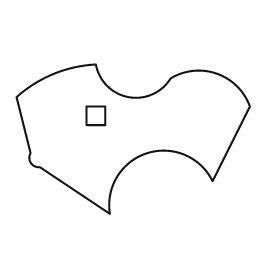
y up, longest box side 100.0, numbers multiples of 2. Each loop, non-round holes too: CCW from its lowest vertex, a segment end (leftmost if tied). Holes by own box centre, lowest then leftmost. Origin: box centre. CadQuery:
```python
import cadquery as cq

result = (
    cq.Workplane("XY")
    .moveTo(-10.0, -32.0)
    .threePointArc((6.0, -6.0), (34.0, -18.0))
    .lineTo(50.0, 14.0)
    .threePointArc((36.0, 28.0), (16.0, 26.0))
    .threePointArc((-2.0, 18.0), (-16.0, 32.0))
    .threePointArc((-34.0, 28.0), (-50.0, 18.0))
    .lineTo(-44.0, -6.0)
    .threePointArc((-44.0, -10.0), (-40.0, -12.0))
    .close()
    .moveTo(-20.0, 6.0)
    .lineTo(-12.0, 6.0)
    .lineTo(-12.0, 14.0)
    .lineTo(-20.0, 14.0)
    .close()
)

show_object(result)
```